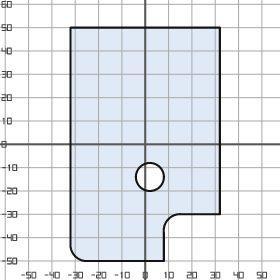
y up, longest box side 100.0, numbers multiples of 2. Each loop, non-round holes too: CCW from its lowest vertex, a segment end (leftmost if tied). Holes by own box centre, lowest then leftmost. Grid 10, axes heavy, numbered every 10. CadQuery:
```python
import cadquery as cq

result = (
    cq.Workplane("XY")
    .moveTo(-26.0, -50.0)
    .lineTo(8.0, -50.0)
    .lineTo(8.0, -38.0)
    .threePointArc((10.0, -32.0), (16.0, -30.0))
    .lineTo(32.0, -30.0)
    .lineTo(32.0, 50.0)
    .lineTo(-32.0, 50.0)
    .lineTo(-32.0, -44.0)
    .threePointArc((-30.0, -48.0), (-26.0, -50.0))
    .close()
    .moveTo(2.0, -14.0)
    .circle(6.0)
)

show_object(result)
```